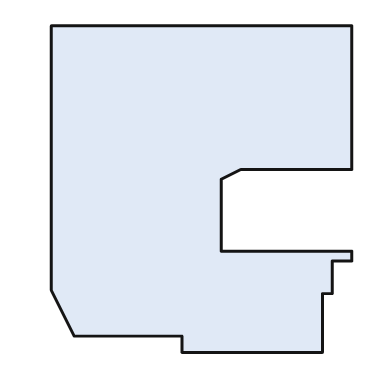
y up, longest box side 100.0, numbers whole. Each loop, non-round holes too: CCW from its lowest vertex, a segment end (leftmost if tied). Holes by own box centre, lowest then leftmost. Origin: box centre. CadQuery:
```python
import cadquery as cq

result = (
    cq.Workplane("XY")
    .moveTo(-6.0, -50.0)
    .lineTo(37.0, -50.0)
    .lineTo(37.0, -32.0)
    .lineTo(40.0, -32.0)
    .lineTo(40.0, -22.0)
    .lineTo(46.0, -22.0)
    .lineTo(46.0, -19.0)
    .lineTo(6.0, -19.0)
    .lineTo(6.0, 3.0)
    .lineTo(12.0, 6.0)
    .lineTo(46.0, 6.0)
    .lineTo(46.0, 50.0)
    .lineTo(-46.0, 50.0)
    .lineTo(-46.0, -31.0)
    .lineTo(-39.0, -45.0)
    .lineTo(-6.0, -45.0)
    .close()
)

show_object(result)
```